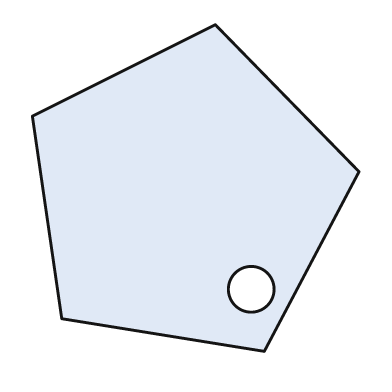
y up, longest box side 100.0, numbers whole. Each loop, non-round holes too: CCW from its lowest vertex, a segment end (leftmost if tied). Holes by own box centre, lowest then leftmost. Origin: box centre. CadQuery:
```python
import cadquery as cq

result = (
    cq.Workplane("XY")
    .moveTo(21.0, -50.0)
    .lineTo(50.0, 5.0)
    .lineTo(6.0, 50.0)
    .lineTo(-50.0, 22.0)
    .lineTo(-41.0, -40.0)
    .close()
    .moveTo(17.0, -31.0)
    .circle(7.0)
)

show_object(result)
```